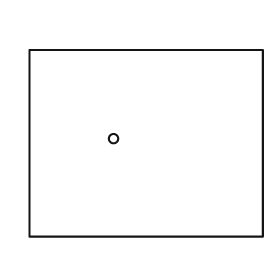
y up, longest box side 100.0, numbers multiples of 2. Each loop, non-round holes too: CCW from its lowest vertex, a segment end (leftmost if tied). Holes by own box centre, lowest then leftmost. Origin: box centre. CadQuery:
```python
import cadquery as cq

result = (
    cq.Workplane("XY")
    .moveTo(-50.0, -40.0)
    .lineTo(50.0, -40.0)
    .lineTo(50.0, 40.0)
    .lineTo(-50.0, 40.0)
    .close()
    .moveTo(-14.0, 2.0)
    .circle(2.0)
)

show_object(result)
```